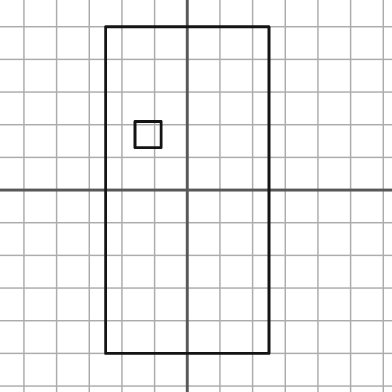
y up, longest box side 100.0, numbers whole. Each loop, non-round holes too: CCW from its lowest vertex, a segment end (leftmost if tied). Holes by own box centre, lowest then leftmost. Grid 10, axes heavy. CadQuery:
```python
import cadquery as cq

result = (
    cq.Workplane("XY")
    .moveTo(-25.0, -50.0)
    .lineTo(25.0, -50.0)
    .lineTo(25.0, 50.0)
    .lineTo(-25.0, 50.0)
    .close()
    .moveTo(-16.0, 13.0)
    .lineTo(-8.0, 13.0)
    .lineTo(-8.0, 21.0)
    .lineTo(-16.0, 21.0)
    .close()
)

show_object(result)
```